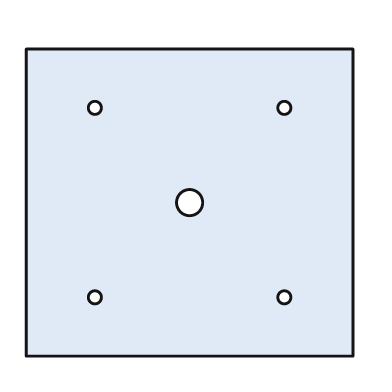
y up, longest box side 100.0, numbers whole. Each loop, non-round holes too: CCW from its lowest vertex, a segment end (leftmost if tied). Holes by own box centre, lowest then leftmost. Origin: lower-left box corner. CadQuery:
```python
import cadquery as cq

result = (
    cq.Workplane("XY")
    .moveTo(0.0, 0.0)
    .lineTo(100.0, 0.0)
    .lineTo(100.0, 94.0)
    .lineTo(0.0, 94.0)
    .close()
    .moveTo(21.0, 18.0)
    .circle(2.0)
    .moveTo(79.0, 18.0)
    .circle(2.0)
    .moveTo(50.0, 47.0)
    .circle(4.0)
    .moveTo(21.0, 76.0)
    .circle(2.0)
    .moveTo(79.0, 76.0)
    .circle(2.0)
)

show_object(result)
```